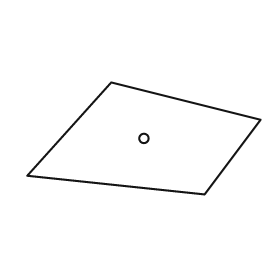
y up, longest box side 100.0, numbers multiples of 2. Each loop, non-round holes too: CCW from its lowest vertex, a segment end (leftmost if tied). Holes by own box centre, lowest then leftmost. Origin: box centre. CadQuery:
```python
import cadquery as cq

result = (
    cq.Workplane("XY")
    .moveTo(26.0, -24.0)
    .lineTo(50.0, 8.0)
    .lineTo(-14.0, 24.0)
    .lineTo(-50.0, -16.0)
    .close()
    .moveTo(0.0, 0.0)
    .circle(2.0)
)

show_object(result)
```